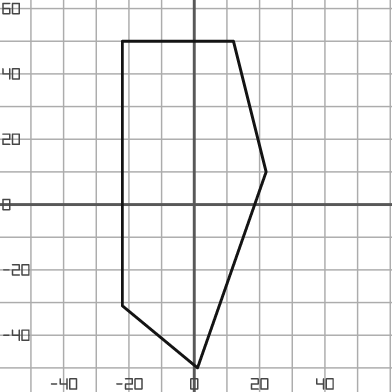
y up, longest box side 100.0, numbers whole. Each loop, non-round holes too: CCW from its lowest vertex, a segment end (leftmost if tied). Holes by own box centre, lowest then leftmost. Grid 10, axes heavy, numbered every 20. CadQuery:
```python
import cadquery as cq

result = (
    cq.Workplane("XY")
    .moveTo(1.0, -50.0)
    .lineTo(22.0, 10.0)
    .lineTo(12.0, 50.0)
    .lineTo(-22.0, 50.0)
    .lineTo(-22.0, -31.0)
    .close()
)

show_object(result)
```